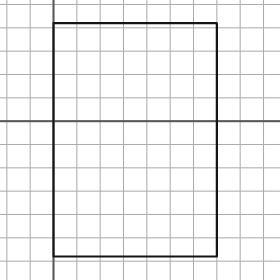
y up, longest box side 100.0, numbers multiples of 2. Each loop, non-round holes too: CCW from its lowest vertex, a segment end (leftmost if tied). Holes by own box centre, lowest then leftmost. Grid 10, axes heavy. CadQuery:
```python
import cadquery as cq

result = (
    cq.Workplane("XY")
    .moveTo(0.0, -58.0)
    .lineTo(70.0, -58.0)
    .lineTo(70.0, 42.0)
    .lineTo(0.0, 42.0)
    .close()
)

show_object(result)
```